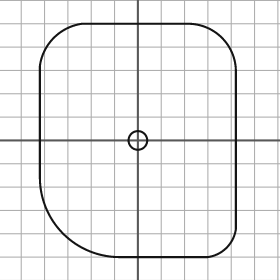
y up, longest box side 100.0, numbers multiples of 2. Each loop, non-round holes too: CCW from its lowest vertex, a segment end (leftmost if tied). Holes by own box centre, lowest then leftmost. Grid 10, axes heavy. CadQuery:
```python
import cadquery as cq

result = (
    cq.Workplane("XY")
    .moveTo(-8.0, -50.0)
    .lineTo(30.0, -50.0)
    .threePointArc((38.0, -46.0), (42.0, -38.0))
    .lineTo(42.0, 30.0)
    .threePointArc((36.0, 44.0), (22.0, 50.0))
    .lineTo(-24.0, 50.0)
    .threePointArc((-36.0, 44.0), (-42.0, 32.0))
    .lineTo(-42.0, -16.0)
    .threePointArc((-32.0, -40.0), (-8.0, -50.0))
    .close()
    .moveTo(0.0, 0.0)
    .circle(4.0)
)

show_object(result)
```